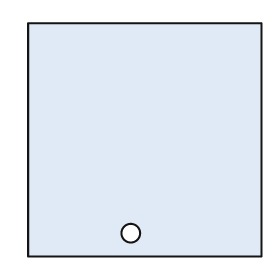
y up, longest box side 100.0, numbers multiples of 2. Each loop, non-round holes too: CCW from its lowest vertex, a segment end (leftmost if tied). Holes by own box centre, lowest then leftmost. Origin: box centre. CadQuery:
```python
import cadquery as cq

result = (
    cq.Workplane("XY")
    .moveTo(-50.0, -50.0)
    .lineTo(50.0, -50.0)
    .lineTo(50.0, 50.0)
    .lineTo(-50.0, 50.0)
    .close()
    .moveTo(-6.0, -40.0)
    .circle(4.0)
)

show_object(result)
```